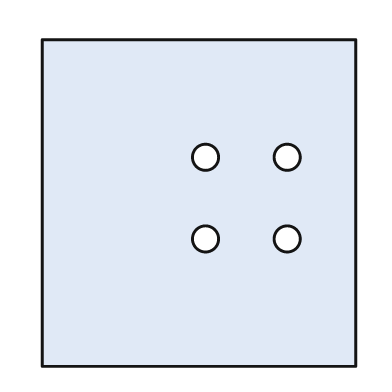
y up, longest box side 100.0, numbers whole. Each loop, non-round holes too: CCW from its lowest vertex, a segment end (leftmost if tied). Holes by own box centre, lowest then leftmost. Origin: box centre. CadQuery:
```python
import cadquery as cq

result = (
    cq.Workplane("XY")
    .moveTo(-48.0, -50.0)
    .lineTo(48.0, -50.0)
    .lineTo(48.0, 50.0)
    .lineTo(-48.0, 50.0)
    .close()
    .moveTo(2.0, -11.0)
    .circle(4.0)
    .moveTo(27.0, -11.0)
    .circle(4.0)
    .moveTo(2.0, 14.0)
    .circle(4.0)
    .moveTo(27.0, 14.0)
    .circle(4.0)
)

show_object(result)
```